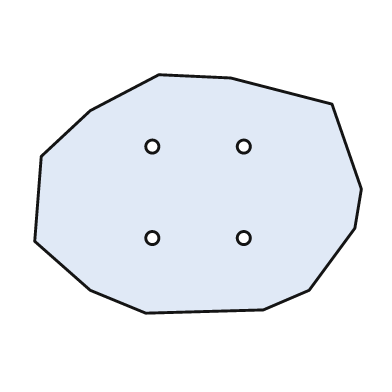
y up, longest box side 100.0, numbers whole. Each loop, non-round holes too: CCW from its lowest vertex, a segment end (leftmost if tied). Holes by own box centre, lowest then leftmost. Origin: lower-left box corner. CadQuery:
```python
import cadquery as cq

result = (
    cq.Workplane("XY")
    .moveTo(34.0, 0.0)
    .lineTo(70.0, 1.0)
    .lineTo(84.0, 7.0)
    .lineTo(98.0, 26.0)
    .lineTo(100.0, 38.0)
    .lineTo(91.0, 64.0)
    .lineTo(60.0, 72.0)
    .lineTo(38.0, 73.0)
    .lineTo(17.0, 62.0)
    .lineTo(2.0, 48.0)
    .lineTo(0.0, 22.0)
    .lineTo(17.0, 7.0)
    .close()
    .moveTo(36.0, 23.0)
    .circle(2.0)
    .moveTo(64.0, 23.0)
    .circle(2.0)
    .moveTo(36.0, 51.0)
    .circle(2.0)
    .moveTo(64.0, 51.0)
    .circle(2.0)
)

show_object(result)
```